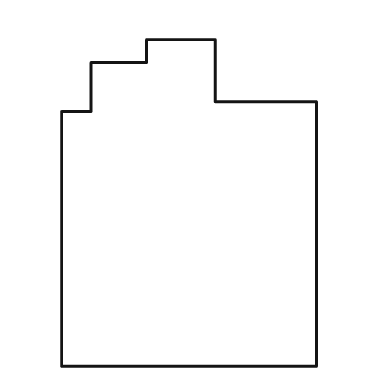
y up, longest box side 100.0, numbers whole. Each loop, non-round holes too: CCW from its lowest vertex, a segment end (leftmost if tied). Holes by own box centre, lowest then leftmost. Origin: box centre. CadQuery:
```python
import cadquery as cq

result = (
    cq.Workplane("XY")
    .moveTo(-39.0, -50.0)
    .lineTo(39.0, -50.0)
    .lineTo(39.0, 31.0)
    .lineTo(8.0, 31.0)
    .lineTo(8.0, 50.0)
    .lineTo(-13.0, 50.0)
    .lineTo(-13.0, 43.0)
    .lineTo(-30.0, 43.0)
    .lineTo(-30.0, 28.0)
    .lineTo(-39.0, 28.0)
    .close()
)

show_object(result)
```